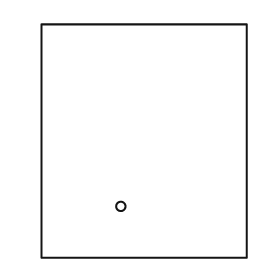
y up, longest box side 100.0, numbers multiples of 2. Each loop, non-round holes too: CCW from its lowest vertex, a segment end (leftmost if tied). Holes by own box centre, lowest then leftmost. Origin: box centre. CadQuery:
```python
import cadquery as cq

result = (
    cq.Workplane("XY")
    .moveTo(-44.0, -50.0)
    .lineTo(44.0, -50.0)
    .lineTo(44.0, 50.0)
    .lineTo(-44.0, 50.0)
    .close()
    .moveTo(-10.0, -28.0)
    .circle(2.0)
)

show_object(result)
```